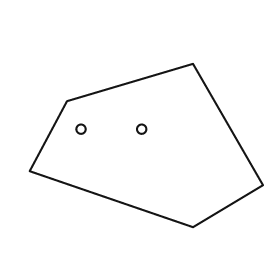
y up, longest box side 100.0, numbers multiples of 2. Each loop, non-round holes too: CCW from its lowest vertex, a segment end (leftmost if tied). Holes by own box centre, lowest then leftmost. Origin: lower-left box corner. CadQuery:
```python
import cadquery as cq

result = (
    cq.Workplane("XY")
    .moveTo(70.0, 0.0)
    .lineTo(100.0, 18.0)
    .lineTo(70.0, 70.0)
    .lineTo(16.0, 54.0)
    .lineTo(0.0, 24.0)
    .close()
    .moveTo(22.0, 42.0)
    .circle(2.0)
    .moveTo(48.0, 42.0)
    .circle(2.0)
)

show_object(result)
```